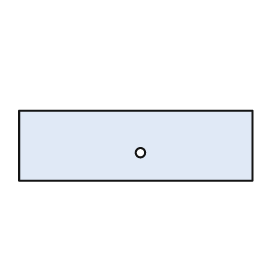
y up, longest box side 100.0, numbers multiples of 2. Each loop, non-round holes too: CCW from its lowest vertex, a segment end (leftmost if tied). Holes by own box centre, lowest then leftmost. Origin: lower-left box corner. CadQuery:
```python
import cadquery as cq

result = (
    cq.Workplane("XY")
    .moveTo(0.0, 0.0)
    .lineTo(100.0, 0.0)
    .lineTo(100.0, 30.0)
    .lineTo(0.0, 30.0)
    .close()
    .moveTo(52.0, 12.0)
    .circle(2.0)
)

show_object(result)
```